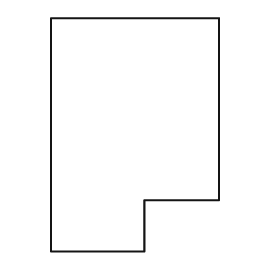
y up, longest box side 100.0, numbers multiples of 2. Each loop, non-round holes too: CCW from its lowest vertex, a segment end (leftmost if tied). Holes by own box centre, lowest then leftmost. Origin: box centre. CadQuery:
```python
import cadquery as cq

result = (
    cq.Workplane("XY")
    .moveTo(-36.0, -50.0)
    .lineTo(4.0, -50.0)
    .lineTo(4.0, -28.0)
    .lineTo(36.0, -28.0)
    .lineTo(36.0, 50.0)
    .lineTo(-36.0, 50.0)
    .close()
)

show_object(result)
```